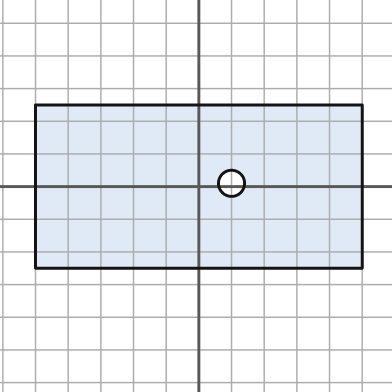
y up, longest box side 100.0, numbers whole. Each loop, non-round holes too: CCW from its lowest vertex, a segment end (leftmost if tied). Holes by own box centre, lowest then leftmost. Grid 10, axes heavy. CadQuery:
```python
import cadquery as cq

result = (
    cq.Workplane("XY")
    .moveTo(-50.0, -25.0)
    .lineTo(50.0, -25.0)
    .lineTo(50.0, 25.0)
    .lineTo(-50.0, 25.0)
    .close()
    .moveTo(10.0, 1.0)
    .circle(4.0)
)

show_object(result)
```